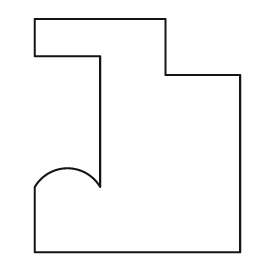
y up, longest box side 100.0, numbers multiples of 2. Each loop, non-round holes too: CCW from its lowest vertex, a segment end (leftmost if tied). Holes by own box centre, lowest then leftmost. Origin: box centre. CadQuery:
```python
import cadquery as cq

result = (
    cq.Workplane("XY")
    .moveTo(-44.0, -50.0)
    .lineTo(44.0, -50.0)
    .lineTo(44.0, 26.0)
    .lineTo(12.0, 26.0)
    .lineTo(12.0, 50.0)
    .lineTo(-44.0, 50.0)
    .lineTo(-44.0, 34.0)
    .lineTo(-16.0, 34.0)
    .lineTo(-16.0, -22.0)
    .threePointArc((-30.0, -14.0), (-44.0, -22.0))
    .close()
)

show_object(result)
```